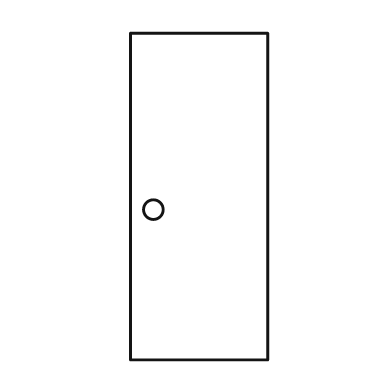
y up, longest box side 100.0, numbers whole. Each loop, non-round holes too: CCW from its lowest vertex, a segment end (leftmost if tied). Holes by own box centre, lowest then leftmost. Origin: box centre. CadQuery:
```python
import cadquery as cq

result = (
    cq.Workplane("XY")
    .moveTo(-21.0, -50.0)
    .lineTo(21.0, -50.0)
    .lineTo(21.0, 50.0)
    .lineTo(-21.0, 50.0)
    .close()
    .moveTo(-14.0, -4.0)
    .circle(3.0)
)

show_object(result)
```